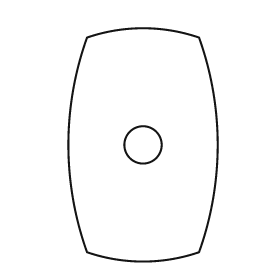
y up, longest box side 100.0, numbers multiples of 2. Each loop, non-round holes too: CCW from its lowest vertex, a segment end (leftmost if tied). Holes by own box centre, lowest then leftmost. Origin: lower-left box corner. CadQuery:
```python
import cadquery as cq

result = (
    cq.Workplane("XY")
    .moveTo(8.0, 4.0)
    .threePointArc((32.0, 0.0), (56.0, 4.0))
    .threePointArc((64.0, 50.0), (56.0, 96.0))
    .threePointArc((32.0, 100.0), (8.0, 96.0))
    .threePointArc((0.0, 50.0), (8.0, 4.0))
    .close()
    .moveTo(32.0, 50.0)
    .circle(8.0)
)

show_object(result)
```